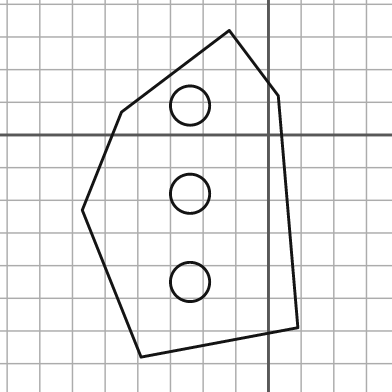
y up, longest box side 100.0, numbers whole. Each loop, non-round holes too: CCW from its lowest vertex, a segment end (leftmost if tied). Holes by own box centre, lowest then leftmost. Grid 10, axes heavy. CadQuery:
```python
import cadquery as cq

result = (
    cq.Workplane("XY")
    .moveTo(-39.0, -68.0)
    .lineTo(9.0, -59.0)
    .lineTo(3.0, 12.0)
    .lineTo(-12.0, 32.0)
    .lineTo(-45.0, 7.0)
    .lineTo(-57.0, -23.0)
    .close()
    .moveTo(-24.0, -45.0)
    .circle(6.0)
    .moveTo(-24.0, -18.0)
    .circle(6.0)
    .moveTo(-24.0, 9.0)
    .circle(6.0)
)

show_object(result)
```